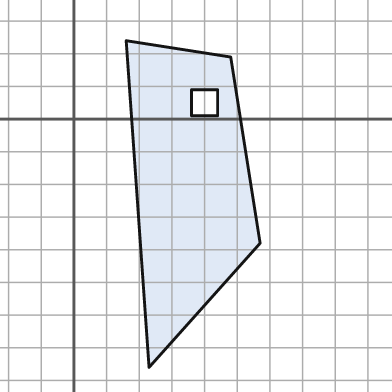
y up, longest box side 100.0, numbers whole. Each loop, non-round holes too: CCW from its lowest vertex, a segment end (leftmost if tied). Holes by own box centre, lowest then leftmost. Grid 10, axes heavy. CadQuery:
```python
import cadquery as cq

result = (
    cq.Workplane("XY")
    .moveTo(23.0, -76.0)
    .lineTo(57.0, -38.0)
    .lineTo(48.0, 19.0)
    .lineTo(16.0, 24.0)
    .close()
    .moveTo(36.0, 1.0)
    .lineTo(44.0, 1.0)
    .lineTo(44.0, 9.0)
    .lineTo(36.0, 9.0)
    .close()
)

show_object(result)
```